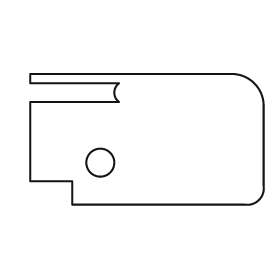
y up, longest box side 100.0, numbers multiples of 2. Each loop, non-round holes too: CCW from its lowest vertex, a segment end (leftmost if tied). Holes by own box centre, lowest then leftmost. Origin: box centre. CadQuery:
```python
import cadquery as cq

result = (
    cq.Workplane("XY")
    .moveTo(-32.0, -28.0)
    .lineTo(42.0, -28.0)
    .threePointArc((48.0, -26.0), (50.0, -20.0))
    .lineTo(50.0, 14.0)
    .threePointArc((46.0, 24.0), (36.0, 28.0))
    .lineTo(-50.0, 28.0)
    .lineTo(-50.0, 24.0)
    .lineTo(-12.0, 24.0)
    .threePointArc((-14.0, 20.0), (-12.0, 16.0))
    .lineTo(-50.0, 16.0)
    .lineTo(-50.0, -18.0)
    .lineTo(-32.0, -18.0)
    .close()
    .moveTo(-20.0, -10.0)
    .circle(6.0)
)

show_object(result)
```